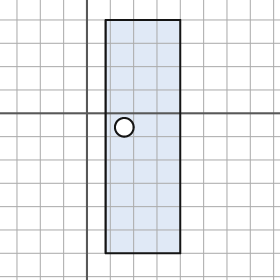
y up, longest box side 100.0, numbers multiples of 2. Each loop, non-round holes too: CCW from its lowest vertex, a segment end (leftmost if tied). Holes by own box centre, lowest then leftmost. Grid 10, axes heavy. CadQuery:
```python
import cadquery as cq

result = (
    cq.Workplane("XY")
    .moveTo(8.0, -60.0)
    .lineTo(40.0, -60.0)
    .lineTo(40.0, 40.0)
    .lineTo(8.0, 40.0)
    .close()
    .moveTo(16.0, -6.0)
    .circle(4.0)
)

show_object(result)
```